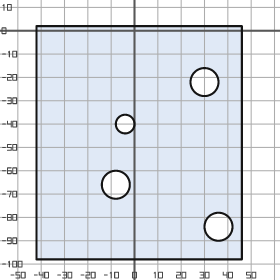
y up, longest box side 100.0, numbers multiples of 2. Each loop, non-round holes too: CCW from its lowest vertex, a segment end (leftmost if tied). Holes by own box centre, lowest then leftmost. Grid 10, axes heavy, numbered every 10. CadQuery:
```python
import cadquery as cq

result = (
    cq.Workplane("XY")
    .moveTo(-42.0, -98.0)
    .lineTo(46.0, -98.0)
    .lineTo(46.0, 2.0)
    .lineTo(-42.0, 2.0)
    .close()
    .moveTo(36.0, -84.0)
    .circle(6.0)
    .moveTo(-8.0, -66.0)
    .circle(6.0)
    .moveTo(-4.0, -40.0)
    .circle(4.0)
    .moveTo(30.0, -22.0)
    .circle(6.0)
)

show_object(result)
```